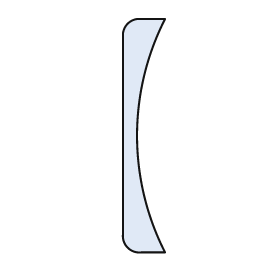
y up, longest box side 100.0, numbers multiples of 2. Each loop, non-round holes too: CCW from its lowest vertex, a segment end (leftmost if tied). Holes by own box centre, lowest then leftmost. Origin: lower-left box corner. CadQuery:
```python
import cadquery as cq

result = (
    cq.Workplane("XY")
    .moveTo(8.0, 0.0)
    .lineTo(18.0, 0.0)
    .threePointArc((6.0, 50.0), (18.0, 100.0))
    .lineTo(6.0, 100.0)
    .threePointArc((2.0, 98.0), (0.0, 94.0))
    .lineTo(0.0, 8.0)
    .threePointArc((2.0, 2.0), (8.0, 0.0))
    .close()
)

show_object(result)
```